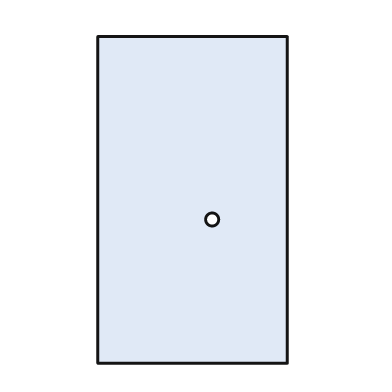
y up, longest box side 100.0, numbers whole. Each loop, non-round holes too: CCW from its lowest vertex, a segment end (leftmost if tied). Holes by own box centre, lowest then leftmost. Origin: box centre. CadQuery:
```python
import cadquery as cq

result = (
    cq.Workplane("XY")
    .moveTo(-29.0, -50.0)
    .lineTo(29.0, -50.0)
    .lineTo(29.0, 50.0)
    .lineTo(-29.0, 50.0)
    .close()
    .moveTo(6.0, -6.0)
    .circle(2.0)
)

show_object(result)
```